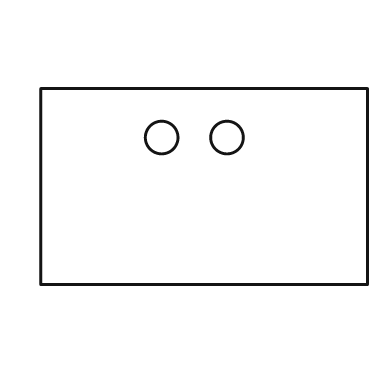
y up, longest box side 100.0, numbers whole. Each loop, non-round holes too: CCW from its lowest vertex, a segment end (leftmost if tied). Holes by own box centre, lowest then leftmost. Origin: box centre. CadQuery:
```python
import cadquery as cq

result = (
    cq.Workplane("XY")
    .moveTo(-50.0, -30.0)
    .lineTo(50.0, -30.0)
    .lineTo(50.0, 30.0)
    .lineTo(-50.0, 30.0)
    .close()
    .moveTo(-13.0, 15.0)
    .circle(5.0)
    .moveTo(7.0, 15.0)
    .circle(5.0)
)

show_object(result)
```